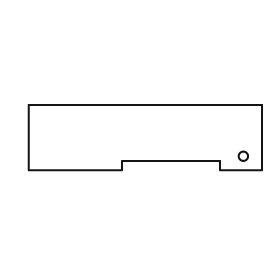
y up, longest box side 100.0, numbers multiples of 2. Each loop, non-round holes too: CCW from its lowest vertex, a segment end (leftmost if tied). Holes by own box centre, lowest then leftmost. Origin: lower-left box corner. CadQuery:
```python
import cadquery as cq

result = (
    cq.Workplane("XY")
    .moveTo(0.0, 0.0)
    .lineTo(40.0, 0.0)
    .lineTo(40.0, 4.0)
    .lineTo(82.0, 4.0)
    .lineTo(82.0, 0.0)
    .lineTo(100.0, 0.0)
    .lineTo(100.0, 28.0)
    .lineTo(0.0, 28.0)
    .close()
    .moveTo(92.0, 6.0)
    .circle(2.0)
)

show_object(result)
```